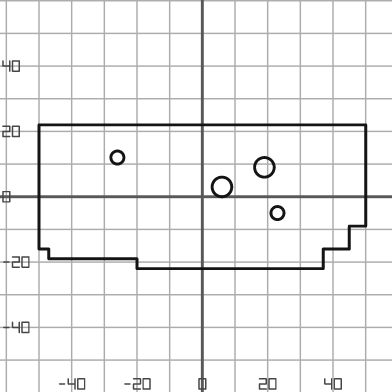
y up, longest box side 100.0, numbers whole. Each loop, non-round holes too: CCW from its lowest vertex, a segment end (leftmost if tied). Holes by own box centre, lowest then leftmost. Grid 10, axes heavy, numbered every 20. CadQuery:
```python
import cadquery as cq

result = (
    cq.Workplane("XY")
    .moveTo(-20.0, -22.0)
    .lineTo(37.0, -22.0)
    .lineTo(37.0, -16.0)
    .lineTo(45.0, -16.0)
    .lineTo(45.0, -9.0)
    .lineTo(50.0, -9.0)
    .lineTo(50.0, 22.0)
    .lineTo(-50.0, 22.0)
    .lineTo(-50.0, -16.0)
    .lineTo(-47.0, -16.0)
    .lineTo(-47.0, -19.0)
    .lineTo(-20.0, -19.0)
    .close()
    .moveTo(23.0, -5.0)
    .circle(2.0)
    .moveTo(6.0, 3.0)
    .circle(3.0)
    .moveTo(19.0, 9.0)
    .circle(3.0)
    .moveTo(-26.0, 12.0)
    .circle(2.0)
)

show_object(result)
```